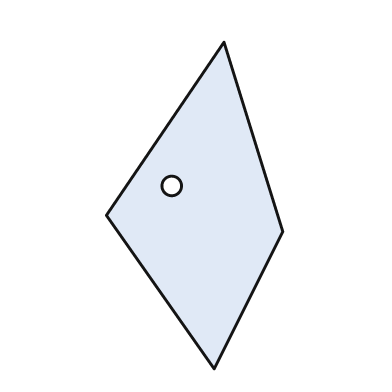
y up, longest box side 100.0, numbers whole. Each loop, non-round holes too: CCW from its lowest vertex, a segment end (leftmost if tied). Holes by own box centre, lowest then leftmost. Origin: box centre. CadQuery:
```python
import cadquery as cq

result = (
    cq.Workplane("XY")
    .moveTo(6.0, -50.0)
    .lineTo(27.0, -8.0)
    .lineTo(9.0, 50.0)
    .lineTo(-27.0, -3.0)
    .close()
    .moveTo(-7.0, 6.0)
    .circle(3.0)
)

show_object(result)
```